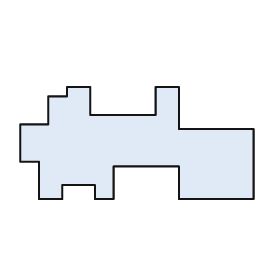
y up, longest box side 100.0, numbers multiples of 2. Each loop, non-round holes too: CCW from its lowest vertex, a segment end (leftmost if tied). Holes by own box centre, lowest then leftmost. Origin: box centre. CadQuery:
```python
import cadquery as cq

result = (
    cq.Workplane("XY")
    .moveTo(-42.0, -24.0)
    .lineTo(-32.0, -24.0)
    .lineTo(-32.0, -18.0)
    .lineTo(-18.0, -18.0)
    .lineTo(-18.0, -24.0)
    .lineTo(-10.0, -24.0)
    .lineTo(-10.0, -10.0)
    .lineTo(18.0, -10.0)
    .lineTo(18.0, -24.0)
    .lineTo(50.0, -24.0)
    .lineTo(50.0, 6.0)
    .lineTo(18.0, 6.0)
    .lineTo(18.0, 24.0)
    .lineTo(8.0, 24.0)
    .lineTo(8.0, 12.0)
    .lineTo(-20.0, 12.0)
    .lineTo(-20.0, 24.0)
    .lineTo(-30.0, 24.0)
    .lineTo(-30.0, 20.0)
    .lineTo(-38.0, 20.0)
    .lineTo(-38.0, 8.0)
    .lineTo(-50.0, 8.0)
    .lineTo(-50.0, -8.0)
    .lineTo(-42.0, -8.0)
    .close()
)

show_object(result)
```